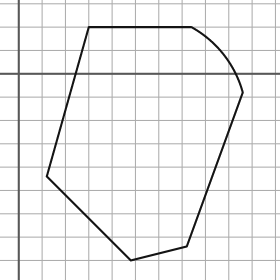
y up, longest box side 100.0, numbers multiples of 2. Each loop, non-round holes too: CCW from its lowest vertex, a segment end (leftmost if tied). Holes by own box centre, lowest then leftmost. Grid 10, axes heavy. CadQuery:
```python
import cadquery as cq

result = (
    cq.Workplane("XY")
    .moveTo(48.0, -80.0)
    .lineTo(72.0, -74.0)
    .lineTo(96.0, -8.0)
    .threePointArc((88.0, 8.0), (74.0, 20.0))
    .lineTo(30.0, 20.0)
    .lineTo(12.0, -44.0)
    .close()
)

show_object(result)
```